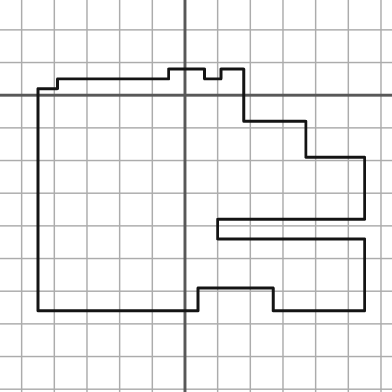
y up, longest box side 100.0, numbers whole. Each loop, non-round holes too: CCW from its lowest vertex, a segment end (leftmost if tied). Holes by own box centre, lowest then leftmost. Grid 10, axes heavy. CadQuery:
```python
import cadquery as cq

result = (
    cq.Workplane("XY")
    .moveTo(-45.0, -66.0)
    .lineTo(4.0, -66.0)
    .lineTo(4.0, -59.0)
    .lineTo(27.0, -59.0)
    .lineTo(27.0, -66.0)
    .lineTo(55.0, -66.0)
    .lineTo(55.0, -44.0)
    .lineTo(10.0, -44.0)
    .lineTo(10.0, -38.0)
    .lineTo(55.0, -38.0)
    .lineTo(55.0, -19.0)
    .lineTo(37.0, -19.0)
    .lineTo(37.0, -8.0)
    .lineTo(18.0, -8.0)
    .lineTo(18.0, 8.0)
    .lineTo(11.0, 8.0)
    .lineTo(11.0, 5.0)
    .lineTo(6.0, 5.0)
    .lineTo(6.0, 8.0)
    .lineTo(-5.0, 8.0)
    .lineTo(-5.0, 5.0)
    .lineTo(-39.0, 5.0)
    .lineTo(-39.0, 2.0)
    .lineTo(-45.0, 2.0)
    .close()
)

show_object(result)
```